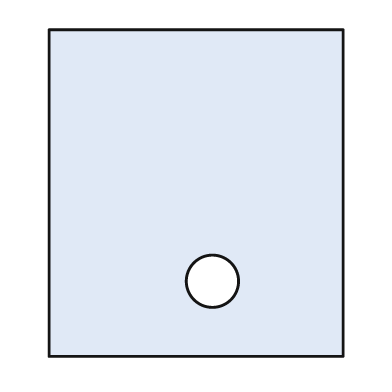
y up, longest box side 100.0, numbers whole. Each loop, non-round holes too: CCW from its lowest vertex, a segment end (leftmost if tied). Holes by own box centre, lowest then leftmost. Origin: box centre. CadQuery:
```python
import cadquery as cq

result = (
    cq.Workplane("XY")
    .moveTo(-45.0, -50.0)
    .lineTo(45.0, -50.0)
    .lineTo(45.0, 50.0)
    .lineTo(-45.0, 50.0)
    .close()
    .moveTo(5.0, -27.0)
    .circle(8.0)
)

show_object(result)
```